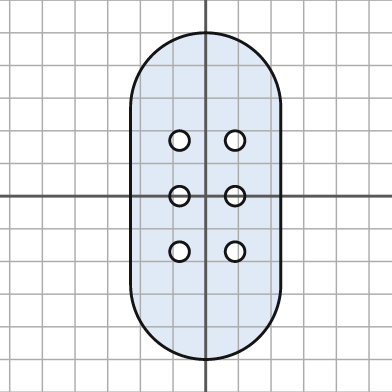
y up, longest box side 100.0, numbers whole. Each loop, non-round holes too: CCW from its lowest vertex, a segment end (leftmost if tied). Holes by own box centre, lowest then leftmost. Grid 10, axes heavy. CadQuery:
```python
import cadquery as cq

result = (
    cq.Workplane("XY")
    .moveTo(-23.0, -27.0)
    .threePointArc((0.0, -50.0), (23.0, -27.0))
    .lineTo(23.0, 27.0)
    .threePointArc((0.0, 50.0), (-23.0, 27.0))
    .close()
    .moveTo(-8.0, -17.0)
    .circle(3.0)
    .moveTo(9.0, -17.0)
    .circle(3.0)
    .moveTo(-8.0, 0.0)
    .circle(3.0)
    .moveTo(9.0, 0.0)
    .circle(3.0)
    .moveTo(-8.0, 17.0)
    .circle(3.0)
    .moveTo(9.0, 17.0)
    .circle(3.0)
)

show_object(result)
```